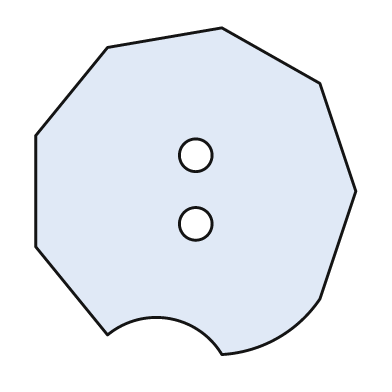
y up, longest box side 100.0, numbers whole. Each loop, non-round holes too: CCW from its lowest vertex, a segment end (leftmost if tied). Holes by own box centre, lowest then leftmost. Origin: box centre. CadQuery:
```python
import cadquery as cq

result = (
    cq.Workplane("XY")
    .moveTo(8.0, -50.0)
    .threePointArc((25.0, -45.0), (38.0, -33.0))
    .lineTo(49.0, 0.0)
    .lineTo(38.0, 33.0)
    .lineTo(8.0, 50.0)
    .lineTo(-27.0, 44.0)
    .lineTo(-49.0, 17.0)
    .lineTo(-49.0, -17.0)
    .lineTo(-27.0, -44.0)
    .threePointArc((-8.0, -39.0), (8.0, -50.0))
    .close()
    .moveTo(0.0, -10.0)
    .circle(5.0)
    .moveTo(0.0, 11.0)
    .circle(5.0)
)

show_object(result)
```